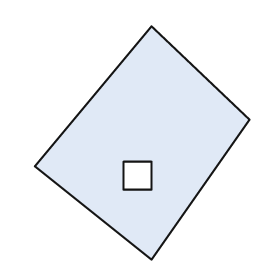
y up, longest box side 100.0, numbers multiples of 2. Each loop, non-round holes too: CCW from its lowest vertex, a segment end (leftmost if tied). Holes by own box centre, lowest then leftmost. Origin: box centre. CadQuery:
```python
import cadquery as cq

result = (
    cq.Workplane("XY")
    .moveTo(4.0, -50.0)
    .lineTo(46.0, 10.0)
    .lineTo(4.0, 50.0)
    .lineTo(-46.0, -10.0)
    .close()
    .moveTo(-8.0, -20.0)
    .lineTo(4.0, -20.0)
    .lineTo(4.0, -8.0)
    .lineTo(-8.0, -8.0)
    .close()
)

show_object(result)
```